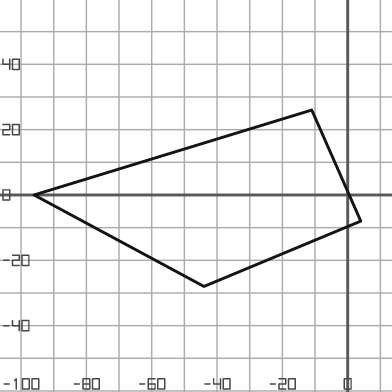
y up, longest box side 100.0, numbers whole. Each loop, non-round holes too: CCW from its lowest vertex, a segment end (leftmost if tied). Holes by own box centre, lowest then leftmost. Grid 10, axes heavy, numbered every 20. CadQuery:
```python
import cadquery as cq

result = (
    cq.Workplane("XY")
    .moveTo(-44.0, -28.0)
    .lineTo(4.0, -8.0)
    .lineTo(-11.0, 26.0)
    .lineTo(-96.0, 0.0)
    .close()
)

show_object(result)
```